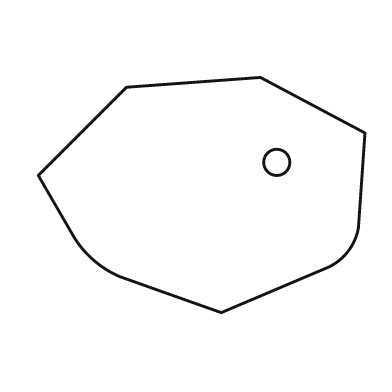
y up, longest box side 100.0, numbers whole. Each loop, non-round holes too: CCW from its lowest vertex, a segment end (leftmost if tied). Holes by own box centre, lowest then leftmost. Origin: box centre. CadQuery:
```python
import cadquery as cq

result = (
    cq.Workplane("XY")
    .moveTo(6.0, -36.0)
    .lineTo(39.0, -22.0)
    .threePointArc((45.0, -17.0), (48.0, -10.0))
    .lineTo(50.0, 19.0)
    .lineTo(18.0, 36.0)
    .lineTo(-23.0, 33.0)
    .lineTo(-50.0, 6.0)
    .lineTo(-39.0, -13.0)
    .threePointArc((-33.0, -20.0), (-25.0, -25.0))
    .close()
    .moveTo(23.0, 10.0)
    .circle(4.0)
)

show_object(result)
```